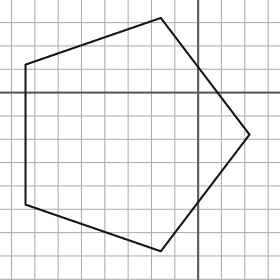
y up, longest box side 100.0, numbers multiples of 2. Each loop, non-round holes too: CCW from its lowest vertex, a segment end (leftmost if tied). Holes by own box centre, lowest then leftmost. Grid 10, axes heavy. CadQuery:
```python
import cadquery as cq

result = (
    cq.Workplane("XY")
    .moveTo(-16.0, -68.0)
    .lineTo(22.0, -18.0)
    .lineTo(-16.0, 32.0)
    .lineTo(-74.0, 12.0)
    .lineTo(-74.0, -48.0)
    .close()
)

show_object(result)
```